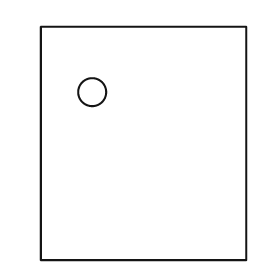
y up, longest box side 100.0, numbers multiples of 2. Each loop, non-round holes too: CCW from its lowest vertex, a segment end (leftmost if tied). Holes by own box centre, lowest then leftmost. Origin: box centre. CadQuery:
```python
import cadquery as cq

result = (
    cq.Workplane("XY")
    .moveTo(-44.0, -50.0)
    .lineTo(44.0, -50.0)
    .lineTo(44.0, 50.0)
    .lineTo(-44.0, 50.0)
    .close()
    .moveTo(-22.0, 22.0)
    .circle(6.0)
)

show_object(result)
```